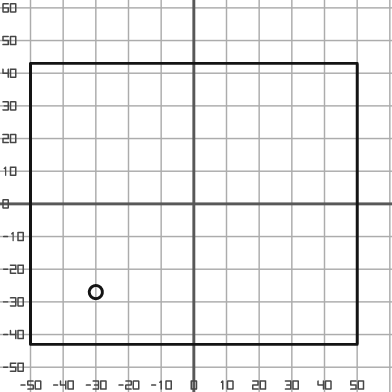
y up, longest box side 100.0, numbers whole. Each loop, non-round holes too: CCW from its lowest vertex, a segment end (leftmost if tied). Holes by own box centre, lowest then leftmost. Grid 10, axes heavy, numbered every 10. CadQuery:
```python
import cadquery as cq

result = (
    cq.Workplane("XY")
    .moveTo(-50.0, -43.0)
    .lineTo(50.0, -43.0)
    .lineTo(50.0, 43.0)
    .lineTo(-50.0, 43.0)
    .close()
    .moveTo(-30.0, -27.0)
    .circle(2.0)
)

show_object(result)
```